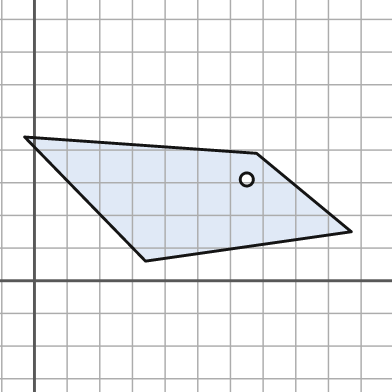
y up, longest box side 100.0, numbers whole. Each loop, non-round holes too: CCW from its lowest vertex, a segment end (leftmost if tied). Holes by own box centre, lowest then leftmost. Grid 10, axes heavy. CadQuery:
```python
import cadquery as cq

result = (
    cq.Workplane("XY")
    .moveTo(34.0, 6.0)
    .lineTo(97.0, 15.0)
    .lineTo(68.0, 39.0)
    .lineTo(-3.0, 44.0)
    .close()
    .moveTo(65.0, 31.0)
    .circle(2.0)
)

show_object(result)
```